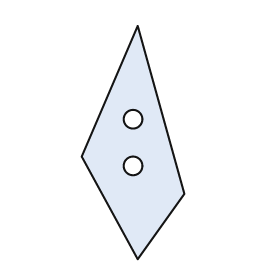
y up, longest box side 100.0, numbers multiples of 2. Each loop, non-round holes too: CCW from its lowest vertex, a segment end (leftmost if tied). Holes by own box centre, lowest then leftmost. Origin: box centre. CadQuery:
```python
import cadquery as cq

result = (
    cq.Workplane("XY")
    .moveTo(2.0, -50.0)
    .lineTo(22.0, -22.0)
    .lineTo(2.0, 50.0)
    .lineTo(-22.0, -6.0)
    .close()
    .moveTo(0.0, -10.0)
    .circle(4.0)
    .moveTo(0.0, 10.0)
    .circle(4.0)
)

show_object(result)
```